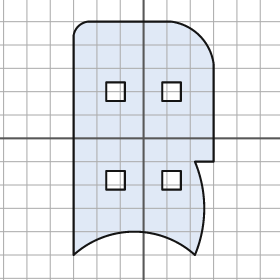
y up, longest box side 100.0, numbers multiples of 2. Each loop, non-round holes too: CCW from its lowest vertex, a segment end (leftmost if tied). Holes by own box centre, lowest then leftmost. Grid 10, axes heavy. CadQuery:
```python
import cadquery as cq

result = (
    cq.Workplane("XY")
    .moveTo(-30.0, -50.0)
    .threePointArc((-4.0, -40.0), (22.0, -50.0))
    .threePointArc((26.0, -30.0), (22.0, -10.0))
    .lineTo(30.0, -10.0)
    .lineTo(30.0, 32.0)
    .threePointArc((24.0, 44.0), (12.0, 50.0))
    .lineTo(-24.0, 50.0)
    .threePointArc((-28.0, 48.0), (-30.0, 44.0))
    .close()
    .moveTo(-16.0, -22.0)
    .lineTo(-8.0, -22.0)
    .lineTo(-8.0, -14.0)
    .lineTo(-16.0, -14.0)
    .close()
    .moveTo(8.0, -22.0)
    .lineTo(16.0, -22.0)
    .lineTo(16.0, -14.0)
    .lineTo(8.0, -14.0)
    .close()
    .moveTo(-16.0, 16.0)
    .lineTo(-8.0, 16.0)
    .lineTo(-8.0, 24.0)
    .lineTo(-16.0, 24.0)
    .close()
    .moveTo(8.0, 16.0)
    .lineTo(16.0, 16.0)
    .lineTo(16.0, 24.0)
    .lineTo(8.0, 24.0)
    .close()
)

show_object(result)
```